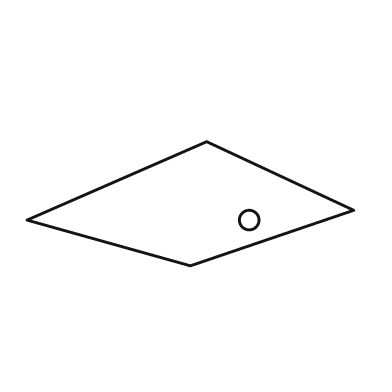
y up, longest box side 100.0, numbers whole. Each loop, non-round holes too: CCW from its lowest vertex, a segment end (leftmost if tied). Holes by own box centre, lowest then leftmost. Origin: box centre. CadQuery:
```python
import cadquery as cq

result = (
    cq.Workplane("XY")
    .moveTo(0.0, -19.0)
    .lineTo(50.0, -2.0)
    .lineTo(5.0, 19.0)
    .lineTo(-50.0, -5.0)
    .close()
    .moveTo(18.0, -5.0)
    .circle(3.0)
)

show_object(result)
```